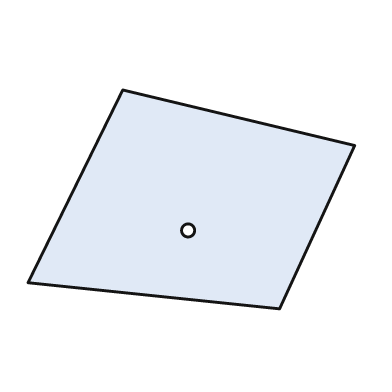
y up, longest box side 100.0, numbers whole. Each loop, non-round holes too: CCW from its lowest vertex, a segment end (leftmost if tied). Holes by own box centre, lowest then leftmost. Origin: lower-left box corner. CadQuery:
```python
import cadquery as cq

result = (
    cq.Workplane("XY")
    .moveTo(77.0, 0.0)
    .lineTo(100.0, 50.0)
    .lineTo(29.0, 67.0)
    .lineTo(0.0, 8.0)
    .close()
    .moveTo(49.0, 24.0)
    .circle(2.0)
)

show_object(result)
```